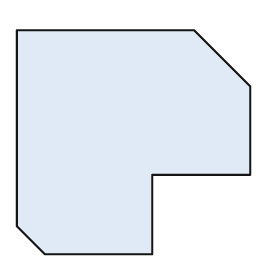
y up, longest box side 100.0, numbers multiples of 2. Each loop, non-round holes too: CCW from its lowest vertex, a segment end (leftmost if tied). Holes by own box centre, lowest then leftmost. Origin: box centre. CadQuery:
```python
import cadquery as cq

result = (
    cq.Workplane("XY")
    .moveTo(-38.0, -48.0)
    .lineTo(8.0, -48.0)
    .lineTo(8.0, -14.0)
    .lineTo(50.0, -14.0)
    .lineTo(50.0, 24.0)
    .lineTo(26.0, 48.0)
    .lineTo(-50.0, 48.0)
    .lineTo(-50.0, -36.0)
    .close()
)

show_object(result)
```